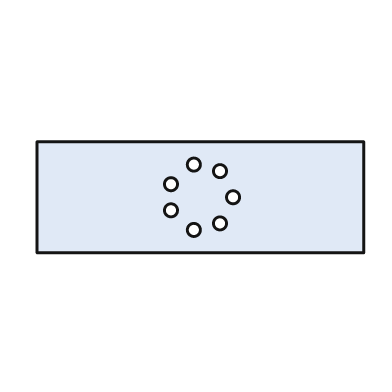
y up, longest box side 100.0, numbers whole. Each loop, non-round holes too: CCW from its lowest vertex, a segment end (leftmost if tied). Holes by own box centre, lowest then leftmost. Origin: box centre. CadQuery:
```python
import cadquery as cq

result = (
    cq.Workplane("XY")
    .moveTo(-50.0, -17.0)
    .lineTo(50.0, -17.0)
    .lineTo(50.0, 17.0)
    .lineTo(-50.0, 17.0)
    .close()
    .moveTo(-2.0, -10.0)
    .circle(2.0)
    .moveTo(6.0, -8.0)
    .circle(2.0)
    .moveTo(-9.0, -4.0)
    .circle(2.0)
    .moveTo(10.0, 0.0)
    .circle(2.0)
    .moveTo(-9.0, 4.0)
    .circle(2.0)
    .moveTo(6.0, 8.0)
    .circle(2.0)
    .moveTo(-2.0, 10.0)
    .circle(2.0)
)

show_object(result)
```